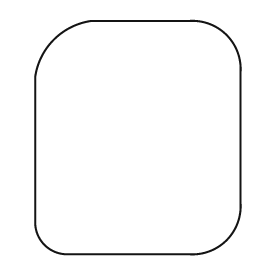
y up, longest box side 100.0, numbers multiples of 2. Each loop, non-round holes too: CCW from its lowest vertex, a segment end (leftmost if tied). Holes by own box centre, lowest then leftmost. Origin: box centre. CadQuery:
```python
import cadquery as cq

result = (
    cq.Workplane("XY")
    .moveTo(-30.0, -50.0)
    .lineTo(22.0, -50.0)
    .threePointArc((38.0, -44.0), (44.0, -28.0))
    .lineTo(44.0, 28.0)
    .threePointArc((38.0, 44.0), (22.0, 50.0))
    .lineTo(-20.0, 50.0)
    .threePointArc((-36.0, 42.0), (-44.0, 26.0))
    .lineTo(-44.0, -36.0)
    .threePointArc((-40.0, -46.0), (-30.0, -50.0))
    .close()
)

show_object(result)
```